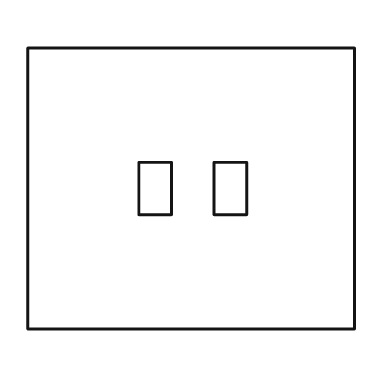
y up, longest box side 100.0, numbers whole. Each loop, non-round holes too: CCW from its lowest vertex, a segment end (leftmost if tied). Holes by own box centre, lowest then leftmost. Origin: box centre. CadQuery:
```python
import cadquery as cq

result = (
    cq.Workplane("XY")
    .moveTo(-50.0, -43.0)
    .lineTo(50.0, -43.0)
    .lineTo(50.0, 43.0)
    .lineTo(-50.0, 43.0)
    .close()
    .moveTo(-16.0, -8.0)
    .lineTo(-6.0, -8.0)
    .lineTo(-6.0, 8.0)
    .lineTo(-16.0, 8.0)
    .close()
    .moveTo(7.0, -8.0)
    .lineTo(17.0, -8.0)
    .lineTo(17.0, 8.0)
    .lineTo(7.0, 8.0)
    .close()
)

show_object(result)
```